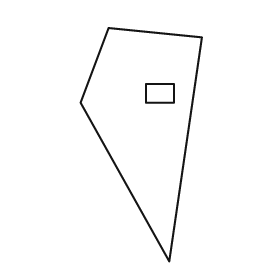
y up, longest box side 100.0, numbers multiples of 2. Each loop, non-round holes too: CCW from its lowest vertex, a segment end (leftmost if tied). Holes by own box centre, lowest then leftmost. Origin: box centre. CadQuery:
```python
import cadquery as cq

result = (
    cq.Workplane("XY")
    .moveTo(12.0, -50.0)
    .lineTo(26.0, 46.0)
    .lineTo(-14.0, 50.0)
    .lineTo(-26.0, 18.0)
    .close()
    .moveTo(2.0, 18.0)
    .lineTo(14.0, 18.0)
    .lineTo(14.0, 26.0)
    .lineTo(2.0, 26.0)
    .close()
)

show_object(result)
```